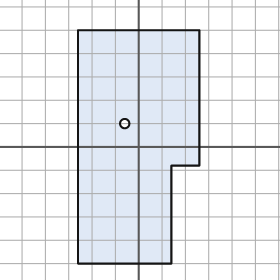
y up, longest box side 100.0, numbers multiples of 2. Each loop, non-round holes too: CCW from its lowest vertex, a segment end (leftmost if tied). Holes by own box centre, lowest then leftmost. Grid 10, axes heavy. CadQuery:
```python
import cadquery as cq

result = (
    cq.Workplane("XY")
    .moveTo(-26.0, -50.0)
    .lineTo(14.0, -50.0)
    .lineTo(14.0, -8.0)
    .lineTo(26.0, -8.0)
    .lineTo(26.0, 50.0)
    .lineTo(-26.0, 50.0)
    .close()
    .moveTo(-6.0, 10.0)
    .circle(2.0)
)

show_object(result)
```